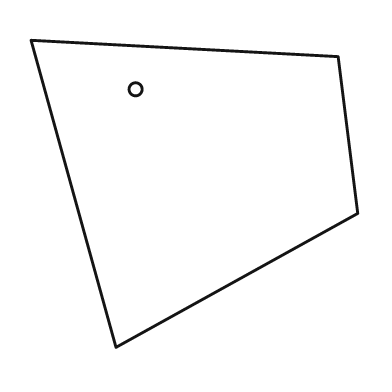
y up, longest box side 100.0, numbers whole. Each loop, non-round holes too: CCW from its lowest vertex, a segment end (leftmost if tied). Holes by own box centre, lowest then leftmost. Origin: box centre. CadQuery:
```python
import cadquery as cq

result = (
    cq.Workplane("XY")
    .moveTo(-24.0, -47.0)
    .lineTo(50.0, -6.0)
    .lineTo(44.0, 42.0)
    .lineTo(-50.0, 47.0)
    .close()
    .moveTo(-18.0, 32.0)
    .circle(2.0)
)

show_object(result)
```